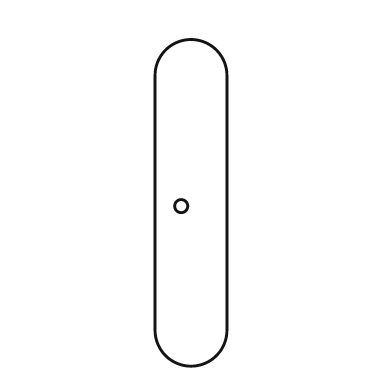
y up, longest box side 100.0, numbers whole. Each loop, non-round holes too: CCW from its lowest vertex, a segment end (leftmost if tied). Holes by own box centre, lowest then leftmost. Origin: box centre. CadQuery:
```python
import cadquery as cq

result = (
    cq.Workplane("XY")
    .moveTo(-11.0, -39.0)
    .threePointArc((0.0, -50.0), (11.0, -39.0))
    .lineTo(11.0, 39.0)
    .threePointArc((0.0, 50.0), (-11.0, 39.0))
    .close()
    .moveTo(-3.0, -1.0)
    .circle(2.0)
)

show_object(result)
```